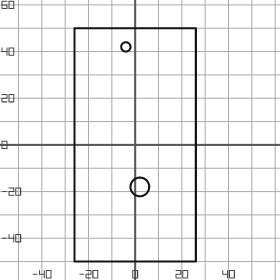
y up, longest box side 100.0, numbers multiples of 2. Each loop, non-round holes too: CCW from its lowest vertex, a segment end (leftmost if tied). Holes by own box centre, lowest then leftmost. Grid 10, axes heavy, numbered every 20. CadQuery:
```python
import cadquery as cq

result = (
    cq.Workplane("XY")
    .moveTo(-26.0, -50.0)
    .lineTo(26.0, -50.0)
    .lineTo(26.0, 50.0)
    .lineTo(-26.0, 50.0)
    .close()
    .moveTo(2.0, -18.0)
    .circle(4.0)
    .moveTo(-4.0, 42.0)
    .circle(2.0)
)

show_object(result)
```